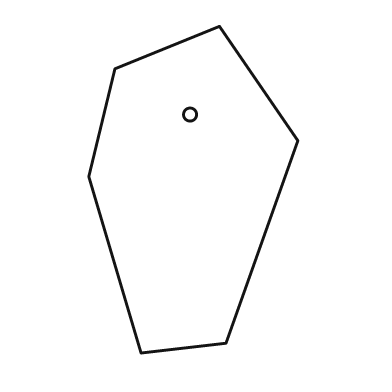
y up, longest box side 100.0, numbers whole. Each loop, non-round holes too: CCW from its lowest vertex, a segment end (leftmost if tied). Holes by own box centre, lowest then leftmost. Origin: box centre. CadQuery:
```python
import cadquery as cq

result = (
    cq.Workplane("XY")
    .moveTo(-16.0, -50.0)
    .lineTo(10.0, -47.0)
    .lineTo(32.0, 15.0)
    .lineTo(8.0, 50.0)
    .lineTo(-24.0, 37.0)
    .lineTo(-32.0, 4.0)
    .close()
    .moveTo(-1.0, 23.0)
    .circle(2.0)
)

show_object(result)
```